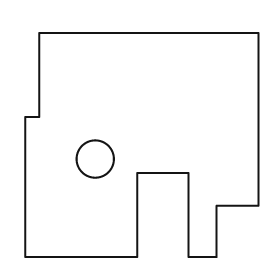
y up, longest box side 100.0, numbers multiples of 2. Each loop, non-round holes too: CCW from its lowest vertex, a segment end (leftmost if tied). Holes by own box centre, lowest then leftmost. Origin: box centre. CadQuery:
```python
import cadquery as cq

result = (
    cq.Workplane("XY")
    .moveTo(-50.0, -48.0)
    .lineTo(-2.0, -48.0)
    .lineTo(-2.0, -12.0)
    .lineTo(20.0, -12.0)
    .lineTo(20.0, -48.0)
    .lineTo(32.0, -48.0)
    .lineTo(32.0, -26.0)
    .lineTo(50.0, -26.0)
    .lineTo(50.0, 48.0)
    .lineTo(-44.0, 48.0)
    .lineTo(-44.0, 12.0)
    .lineTo(-50.0, 12.0)
    .close()
    .moveTo(-20.0, -6.0)
    .circle(8.0)
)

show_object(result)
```